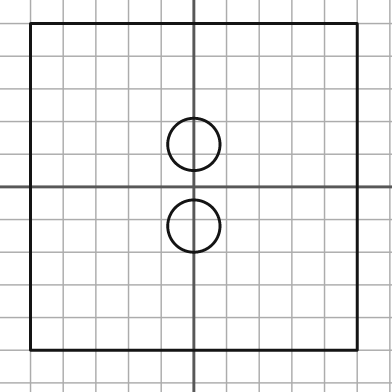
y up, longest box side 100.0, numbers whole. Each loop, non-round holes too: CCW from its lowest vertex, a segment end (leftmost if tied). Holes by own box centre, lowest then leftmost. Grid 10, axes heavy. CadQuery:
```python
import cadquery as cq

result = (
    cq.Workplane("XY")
    .moveTo(-50.0, -50.0)
    .lineTo(50.0, -50.0)
    .lineTo(50.0, 50.0)
    .lineTo(-50.0, 50.0)
    .close()
    .moveTo(0.0, -12.0)
    .circle(8.0)
    .moveTo(0.0, 13.0)
    .circle(8.0)
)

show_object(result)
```